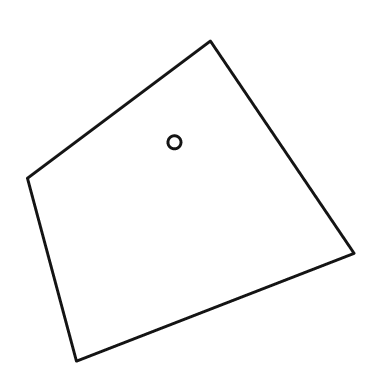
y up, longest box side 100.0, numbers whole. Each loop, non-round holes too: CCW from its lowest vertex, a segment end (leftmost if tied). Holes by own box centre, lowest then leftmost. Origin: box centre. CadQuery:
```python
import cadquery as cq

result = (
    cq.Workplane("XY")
    .moveTo(-35.0, -49.0)
    .lineTo(50.0, -16.0)
    .lineTo(6.0, 49.0)
    .lineTo(-50.0, 7.0)
    .close()
    .moveTo(-5.0, 18.0)
    .circle(2.0)
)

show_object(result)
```